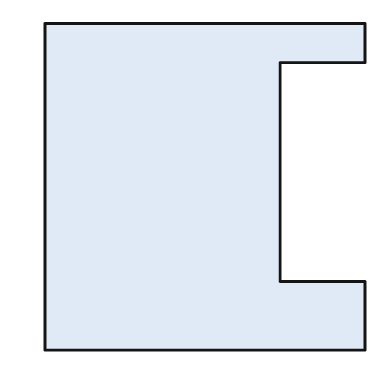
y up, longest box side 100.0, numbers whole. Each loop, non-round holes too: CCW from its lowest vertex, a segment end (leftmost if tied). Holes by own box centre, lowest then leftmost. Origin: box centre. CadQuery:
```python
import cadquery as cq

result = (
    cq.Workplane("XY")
    .moveTo(-49.0, -50.0)
    .lineTo(49.0, -50.0)
    .lineTo(49.0, -29.0)
    .lineTo(23.0, -29.0)
    .lineTo(23.0, 38.0)
    .lineTo(49.0, 38.0)
    .lineTo(49.0, 50.0)
    .lineTo(-49.0, 50.0)
    .close()
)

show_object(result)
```